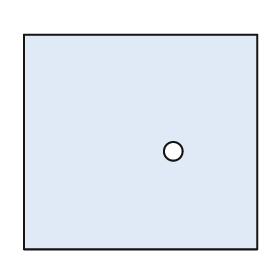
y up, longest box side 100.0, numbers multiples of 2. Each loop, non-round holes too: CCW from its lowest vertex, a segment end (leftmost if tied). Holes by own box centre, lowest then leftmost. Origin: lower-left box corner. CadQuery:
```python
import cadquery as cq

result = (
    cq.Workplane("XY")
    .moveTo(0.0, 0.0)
    .lineTo(100.0, 0.0)
    .lineTo(100.0, 92.0)
    .lineTo(0.0, 92.0)
    .close()
    .moveTo(64.0, 42.0)
    .circle(4.0)
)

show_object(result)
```